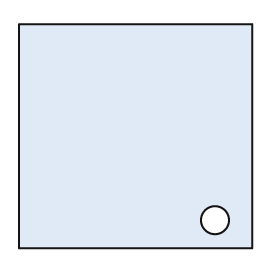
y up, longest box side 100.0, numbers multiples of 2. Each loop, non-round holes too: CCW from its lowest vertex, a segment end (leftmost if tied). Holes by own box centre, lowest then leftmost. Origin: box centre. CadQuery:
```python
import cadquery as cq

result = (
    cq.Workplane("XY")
    .moveTo(-50.0, -48.0)
    .lineTo(50.0, -48.0)
    .lineTo(50.0, 48.0)
    .lineTo(-50.0, 48.0)
    .close()
    .moveTo(34.0, -36.0)
    .circle(6.0)
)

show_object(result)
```